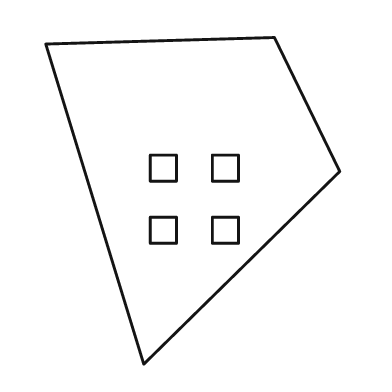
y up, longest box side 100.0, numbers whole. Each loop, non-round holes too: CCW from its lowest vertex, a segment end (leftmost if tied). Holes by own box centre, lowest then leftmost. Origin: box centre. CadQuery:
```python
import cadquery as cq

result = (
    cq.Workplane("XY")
    .moveTo(-15.0, -50.0)
    .lineTo(45.0, 9.0)
    .lineTo(25.0, 50.0)
    .lineTo(-45.0, 48.0)
    .close()
    .moveTo(-13.0, -13.0)
    .lineTo(-5.0, -13.0)
    .lineTo(-5.0, -5.0)
    .lineTo(-13.0, -5.0)
    .close()
    .moveTo(6.0, -13.0)
    .lineTo(14.0, -13.0)
    .lineTo(14.0, -5.0)
    .lineTo(6.0, -5.0)
    .close()
    .moveTo(-13.0, 6.0)
    .lineTo(-5.0, 6.0)
    .lineTo(-5.0, 14.0)
    .lineTo(-13.0, 14.0)
    .close()
    .moveTo(6.0, 6.0)
    .lineTo(14.0, 6.0)
    .lineTo(14.0, 14.0)
    .lineTo(6.0, 14.0)
    .close()
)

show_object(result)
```